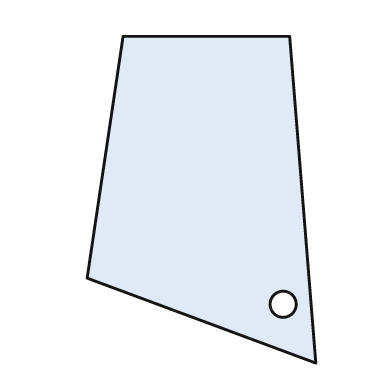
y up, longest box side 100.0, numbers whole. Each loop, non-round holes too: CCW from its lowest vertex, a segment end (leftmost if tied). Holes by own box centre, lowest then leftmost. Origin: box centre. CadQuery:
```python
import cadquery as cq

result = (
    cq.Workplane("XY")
    .moveTo(35.0, -50.0)
    .lineTo(27.0, 50.0)
    .lineTo(-24.0, 50.0)
    .lineTo(-35.0, -24.0)
    .close()
    .moveTo(25.0, -32.0)
    .circle(4.0)
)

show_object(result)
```